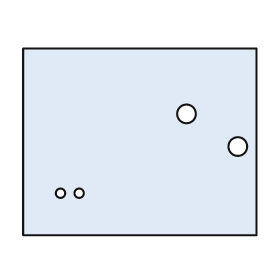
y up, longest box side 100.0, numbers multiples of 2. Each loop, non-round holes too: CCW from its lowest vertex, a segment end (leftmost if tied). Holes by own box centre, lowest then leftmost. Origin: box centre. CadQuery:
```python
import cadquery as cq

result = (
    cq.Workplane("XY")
    .moveTo(-50.0, -40.0)
    .lineTo(50.0, -40.0)
    .lineTo(50.0, 40.0)
    .lineTo(-50.0, 40.0)
    .close()
    .moveTo(-34.0, -22.0)
    .circle(2.0)
    .moveTo(-26.0, -22.0)
    .circle(2.0)
    .moveTo(42.0, -2.0)
    .circle(4.0)
    .moveTo(20.0, 12.0)
    .circle(4.0)
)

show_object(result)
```